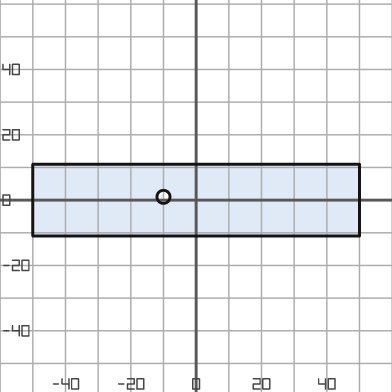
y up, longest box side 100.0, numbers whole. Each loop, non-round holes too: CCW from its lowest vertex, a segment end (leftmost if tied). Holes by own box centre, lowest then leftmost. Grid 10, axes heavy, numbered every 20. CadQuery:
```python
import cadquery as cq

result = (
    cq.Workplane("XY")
    .moveTo(-50.0, -11.0)
    .lineTo(50.0, -11.0)
    .lineTo(50.0, 11.0)
    .lineTo(-50.0, 11.0)
    .close()
    .moveTo(-10.0, 1.0)
    .circle(2.0)
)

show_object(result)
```